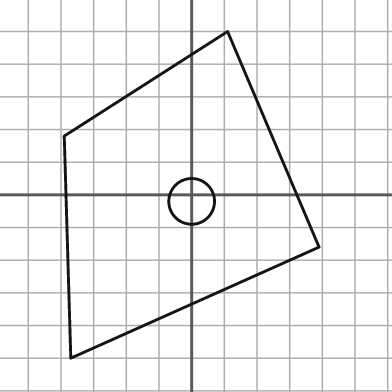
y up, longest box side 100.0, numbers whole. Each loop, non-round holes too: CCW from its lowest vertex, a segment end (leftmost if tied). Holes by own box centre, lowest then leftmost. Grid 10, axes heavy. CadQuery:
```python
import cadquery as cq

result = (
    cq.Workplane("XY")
    .moveTo(-37.0, -50.0)
    .lineTo(39.0, -16.0)
    .lineTo(11.0, 50.0)
    .lineTo(-39.0, 18.0)
    .close()
    .moveTo(0.0, -2.0)
    .circle(7.0)
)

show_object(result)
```